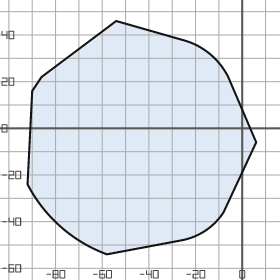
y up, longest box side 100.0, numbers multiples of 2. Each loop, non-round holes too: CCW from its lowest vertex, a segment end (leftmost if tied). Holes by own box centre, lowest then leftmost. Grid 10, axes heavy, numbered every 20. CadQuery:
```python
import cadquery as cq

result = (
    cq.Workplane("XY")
    .moveTo(-58.0, -54.0)
    .lineTo(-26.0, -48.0)
    .threePointArc((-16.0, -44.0), (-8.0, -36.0))
    .lineTo(6.0, -6.0)
    .lineTo(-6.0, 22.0)
    .threePointArc((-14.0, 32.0), (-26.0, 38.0))
    .lineTo(-54.0, 46.0)
    .lineTo(-86.0, 22.0)
    .lineTo(-90.0, 16.0)
    .lineTo(-92.0, -24.0)
    .threePointArc((-78.0, -42.0), (-58.0, -54.0))
    .close()
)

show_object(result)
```